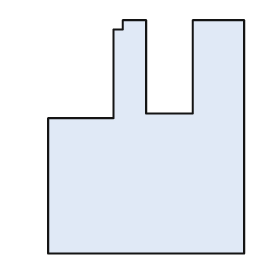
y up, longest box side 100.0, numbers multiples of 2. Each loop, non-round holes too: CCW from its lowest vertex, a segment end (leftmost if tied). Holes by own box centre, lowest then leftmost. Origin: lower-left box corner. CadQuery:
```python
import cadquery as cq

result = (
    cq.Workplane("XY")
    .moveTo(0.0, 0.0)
    .lineTo(84.0, 0.0)
    .lineTo(84.0, 100.0)
    .lineTo(62.0, 100.0)
    .lineTo(62.0, 60.0)
    .lineTo(42.0, 60.0)
    .lineTo(42.0, 100.0)
    .lineTo(32.0, 100.0)
    .lineTo(32.0, 96.0)
    .lineTo(28.0, 96.0)
    .lineTo(28.0, 58.0)
    .lineTo(0.0, 58.0)
    .close()
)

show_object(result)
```